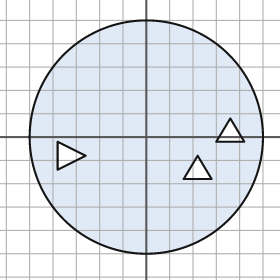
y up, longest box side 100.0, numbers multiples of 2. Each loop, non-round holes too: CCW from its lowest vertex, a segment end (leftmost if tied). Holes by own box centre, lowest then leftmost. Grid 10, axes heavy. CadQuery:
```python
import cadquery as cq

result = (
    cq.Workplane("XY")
    .moveTo(0.0, 0.0)
    .circle(50.0)
    .moveTo(16.0, -18.0)
    .lineTo(28.0, -18.0)
    .lineTo(22.0, -8.0)
    .close()
    .moveTo(-38.0, -14.0)
    .lineTo(-26.0, -8.0)
    .lineTo(-38.0, -2.0)
    .close()
    .moveTo(30.0, -2.0)
    .lineTo(42.0, -2.0)
    .lineTo(36.0, 8.0)
    .close()
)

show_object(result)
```